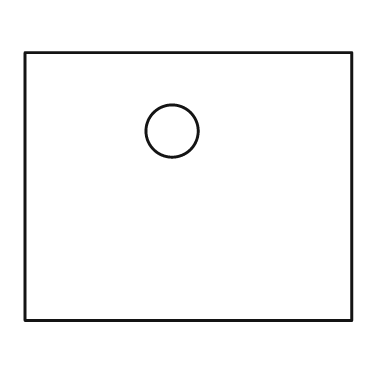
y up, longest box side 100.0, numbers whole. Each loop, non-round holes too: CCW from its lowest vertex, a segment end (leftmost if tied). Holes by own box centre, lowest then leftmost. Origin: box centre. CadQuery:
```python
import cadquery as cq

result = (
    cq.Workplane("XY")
    .moveTo(-50.0, -41.0)
    .lineTo(50.0, -41.0)
    .lineTo(50.0, 41.0)
    .lineTo(-50.0, 41.0)
    .close()
    .moveTo(-5.0, 17.0)
    .circle(8.0)
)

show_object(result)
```